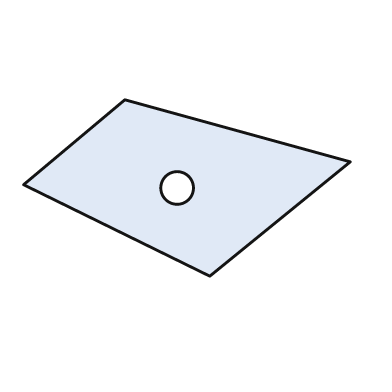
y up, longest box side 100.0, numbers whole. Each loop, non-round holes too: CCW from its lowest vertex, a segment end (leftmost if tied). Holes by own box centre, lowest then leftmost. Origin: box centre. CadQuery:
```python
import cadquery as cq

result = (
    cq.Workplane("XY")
    .moveTo(7.0, -27.0)
    .lineTo(50.0, 8.0)
    .lineTo(-19.0, 27.0)
    .lineTo(-50.0, 1.0)
    .close()
    .moveTo(-3.0, 0.0)
    .circle(5.0)
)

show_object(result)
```